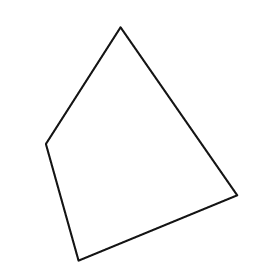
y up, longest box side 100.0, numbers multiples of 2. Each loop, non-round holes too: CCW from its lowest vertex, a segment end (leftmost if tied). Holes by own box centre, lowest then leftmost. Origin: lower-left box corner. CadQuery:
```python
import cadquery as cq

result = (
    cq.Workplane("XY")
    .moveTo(14.0, 0.0)
    .lineTo(82.0, 28.0)
    .lineTo(32.0, 100.0)
    .lineTo(0.0, 50.0)
    .close()
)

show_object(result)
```